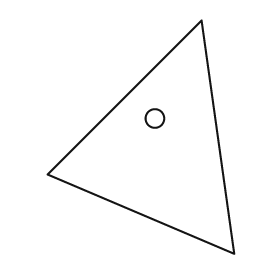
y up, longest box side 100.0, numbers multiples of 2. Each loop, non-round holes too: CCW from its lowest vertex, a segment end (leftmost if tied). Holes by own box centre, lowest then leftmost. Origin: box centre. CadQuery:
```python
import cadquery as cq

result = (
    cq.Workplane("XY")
    .moveTo(40.0, -50.0)
    .lineTo(26.0, 50.0)
    .lineTo(-40.0, -16.0)
    .close()
    .moveTo(6.0, 8.0)
    .circle(4.0)
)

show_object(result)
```